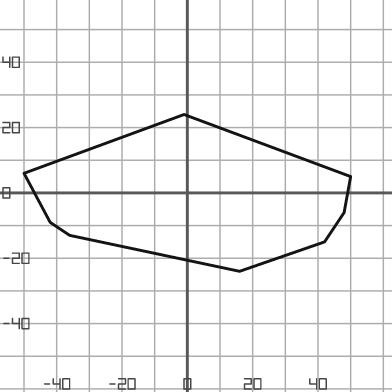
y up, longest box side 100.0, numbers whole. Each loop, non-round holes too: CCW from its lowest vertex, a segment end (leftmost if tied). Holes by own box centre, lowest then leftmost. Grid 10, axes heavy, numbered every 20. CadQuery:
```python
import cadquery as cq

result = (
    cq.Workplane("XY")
    .moveTo(16.0, -24.0)
    .lineTo(42.0, -15.0)
    .lineTo(48.0, -6.0)
    .lineTo(50.0, 5.0)
    .lineTo(-1.0, 24.0)
    .lineTo(-50.0, 6.0)
    .lineTo(-42.0, -9.0)
    .lineTo(-36.0, -13.0)
    .close()
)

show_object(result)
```